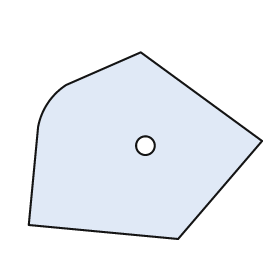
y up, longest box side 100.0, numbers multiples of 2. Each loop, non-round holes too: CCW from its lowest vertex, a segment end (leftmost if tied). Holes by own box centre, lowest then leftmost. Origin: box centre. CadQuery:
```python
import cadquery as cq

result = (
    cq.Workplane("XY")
    .moveTo(14.0, -40.0)
    .lineTo(50.0, 2.0)
    .lineTo(-2.0, 40.0)
    .lineTo(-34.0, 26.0)
    .threePointArc((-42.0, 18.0), (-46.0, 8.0))
    .lineTo(-50.0, -34.0)
    .close()
    .moveTo(0.0, 0.0)
    .circle(4.0)
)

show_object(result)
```